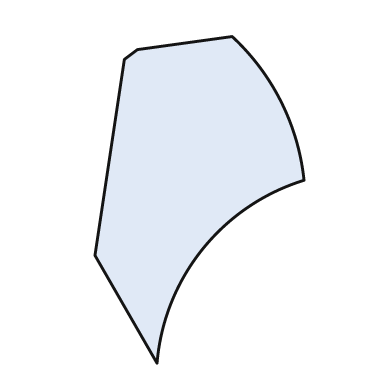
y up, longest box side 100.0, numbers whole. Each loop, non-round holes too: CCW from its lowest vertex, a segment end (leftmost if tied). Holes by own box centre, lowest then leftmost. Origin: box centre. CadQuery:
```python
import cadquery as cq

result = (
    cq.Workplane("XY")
    .moveTo(-13.0, -50.0)
    .threePointArc((1.0, -15.0), (32.0, 6.0))
    .threePointArc((25.0, 30.0), (10.0, 50.0))
    .lineTo(-19.0, 46.0)
    .lineTo(-23.0, 43.0)
    .lineTo(-32.0, -17.0)
    .close()
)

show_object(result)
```